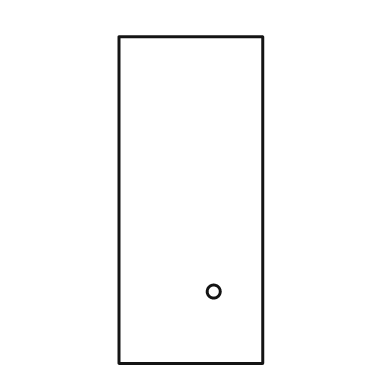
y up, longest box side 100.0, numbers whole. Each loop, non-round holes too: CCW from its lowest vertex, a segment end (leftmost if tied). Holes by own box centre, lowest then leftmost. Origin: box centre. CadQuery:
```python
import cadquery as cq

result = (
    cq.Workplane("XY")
    .moveTo(-22.0, -50.0)
    .lineTo(22.0, -50.0)
    .lineTo(22.0, 50.0)
    .lineTo(-22.0, 50.0)
    .close()
    .moveTo(7.0, -28.0)
    .circle(2.0)
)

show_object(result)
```